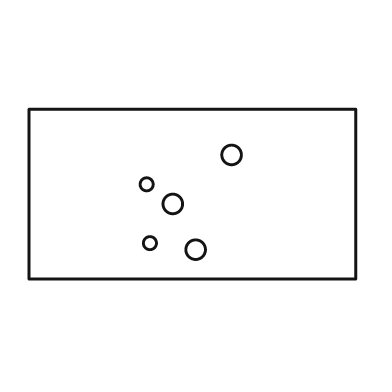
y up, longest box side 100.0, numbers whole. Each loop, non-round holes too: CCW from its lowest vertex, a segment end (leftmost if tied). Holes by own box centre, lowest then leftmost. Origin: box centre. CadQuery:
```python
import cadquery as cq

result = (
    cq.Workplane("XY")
    .moveTo(-50.0, -26.0)
    .lineTo(50.0, -26.0)
    .lineTo(50.0, 26.0)
    .lineTo(-50.0, 26.0)
    .close()
    .moveTo(1.0, -17.0)
    .circle(3.0)
    .moveTo(-13.0, -15.0)
    .circle(2.0)
    .moveTo(-6.0, -3.0)
    .circle(3.0)
    .moveTo(-14.0, 3.0)
    .circle(2.0)
    .moveTo(12.0, 12.0)
    .circle(3.0)
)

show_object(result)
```